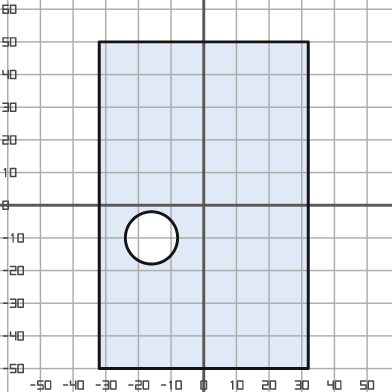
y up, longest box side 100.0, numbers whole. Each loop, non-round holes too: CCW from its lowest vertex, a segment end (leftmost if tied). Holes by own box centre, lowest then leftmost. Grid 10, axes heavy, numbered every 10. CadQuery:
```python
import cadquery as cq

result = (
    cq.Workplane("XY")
    .moveTo(-32.0, -50.0)
    .lineTo(32.0, -50.0)
    .lineTo(32.0, 50.0)
    .lineTo(-32.0, 50.0)
    .close()
    .moveTo(-16.0, -10.0)
    .circle(8.0)
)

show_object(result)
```